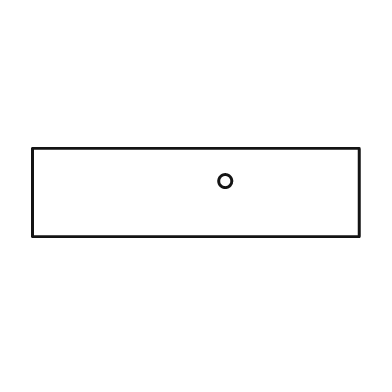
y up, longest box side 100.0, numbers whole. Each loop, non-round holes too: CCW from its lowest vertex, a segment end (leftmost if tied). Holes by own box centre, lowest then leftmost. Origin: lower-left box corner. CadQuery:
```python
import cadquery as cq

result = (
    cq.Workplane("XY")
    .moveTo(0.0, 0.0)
    .lineTo(100.0, 0.0)
    .lineTo(100.0, 27.0)
    .lineTo(0.0, 27.0)
    .close()
    .moveTo(59.0, 17.0)
    .circle(2.0)
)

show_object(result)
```